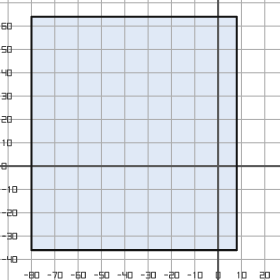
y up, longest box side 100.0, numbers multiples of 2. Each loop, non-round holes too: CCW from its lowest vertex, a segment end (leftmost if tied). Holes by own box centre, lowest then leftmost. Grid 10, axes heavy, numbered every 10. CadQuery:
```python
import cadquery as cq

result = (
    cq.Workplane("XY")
    .moveTo(-80.0, -36.0)
    .lineTo(8.0, -36.0)
    .lineTo(8.0, 64.0)
    .lineTo(-80.0, 64.0)
    .close()
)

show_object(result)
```